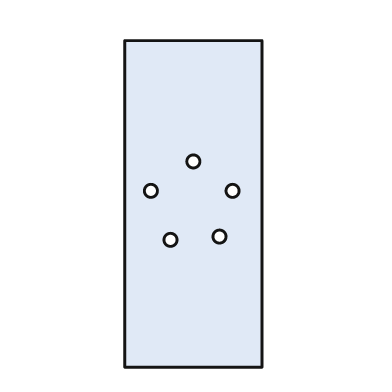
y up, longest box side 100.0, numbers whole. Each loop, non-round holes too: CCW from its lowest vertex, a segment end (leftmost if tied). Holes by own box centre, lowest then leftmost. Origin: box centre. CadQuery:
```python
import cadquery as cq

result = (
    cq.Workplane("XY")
    .moveTo(-21.0, -50.0)
    .lineTo(21.0, -50.0)
    .lineTo(21.0, 50.0)
    .lineTo(-21.0, 50.0)
    .close()
    .moveTo(-7.0, -11.0)
    .circle(2.0)
    .moveTo(8.0, -10.0)
    .circle(2.0)
    .moveTo(-13.0, 4.0)
    .circle(2.0)
    .moveTo(12.0, 4.0)
    .circle(2.0)
    .moveTo(0.0, 13.0)
    .circle(2.0)
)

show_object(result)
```